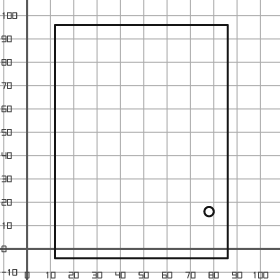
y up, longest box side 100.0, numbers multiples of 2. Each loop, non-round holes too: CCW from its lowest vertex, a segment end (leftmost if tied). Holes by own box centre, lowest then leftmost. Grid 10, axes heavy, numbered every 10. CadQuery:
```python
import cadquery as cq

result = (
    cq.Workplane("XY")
    .moveTo(12.0, -4.0)
    .lineTo(86.0, -4.0)
    .lineTo(86.0, 96.0)
    .lineTo(12.0, 96.0)
    .close()
    .moveTo(78.0, 16.0)
    .circle(2.0)
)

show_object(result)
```